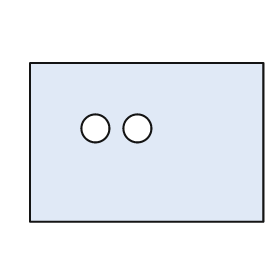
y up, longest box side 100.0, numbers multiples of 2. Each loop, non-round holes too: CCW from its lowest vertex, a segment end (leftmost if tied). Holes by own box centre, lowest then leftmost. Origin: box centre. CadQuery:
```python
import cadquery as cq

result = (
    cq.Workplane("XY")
    .moveTo(-50.0, -34.0)
    .lineTo(50.0, -34.0)
    .lineTo(50.0, 34.0)
    .lineTo(-50.0, 34.0)
    .close()
    .moveTo(-22.0, 6.0)
    .circle(6.0)
    .moveTo(-4.0, 6.0)
    .circle(6.0)
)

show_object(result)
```